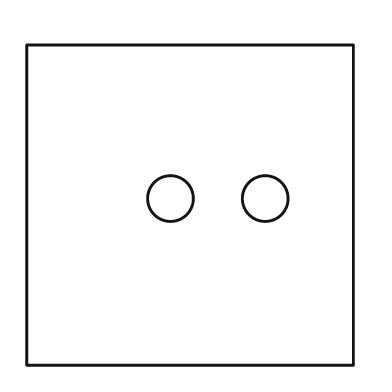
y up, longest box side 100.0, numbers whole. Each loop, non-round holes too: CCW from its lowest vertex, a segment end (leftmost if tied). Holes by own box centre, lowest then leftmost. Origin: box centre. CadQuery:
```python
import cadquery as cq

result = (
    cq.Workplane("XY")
    .moveTo(-50.0, -49.0)
    .lineTo(50.0, -49.0)
    .lineTo(50.0, 49.0)
    .lineTo(-50.0, 49.0)
    .close()
    .moveTo(-6.0, 2.0)
    .circle(7.0)
    .moveTo(23.0, 2.0)
    .circle(7.0)
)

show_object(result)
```